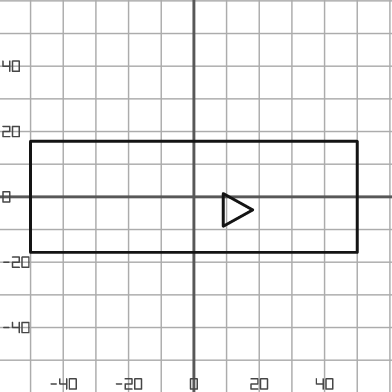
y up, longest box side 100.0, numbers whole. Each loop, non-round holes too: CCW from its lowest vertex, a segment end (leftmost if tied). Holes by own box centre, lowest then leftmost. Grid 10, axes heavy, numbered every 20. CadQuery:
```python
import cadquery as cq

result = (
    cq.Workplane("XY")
    .moveTo(-50.0, -17.0)
    .lineTo(50.0, -17.0)
    .lineTo(50.0, 17.0)
    .lineTo(-50.0, 17.0)
    .close()
    .moveTo(9.0, -9.0)
    .lineTo(18.0, -4.0)
    .lineTo(9.0, 1.0)
    .close()
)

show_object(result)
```